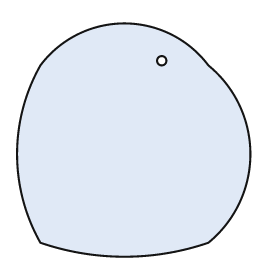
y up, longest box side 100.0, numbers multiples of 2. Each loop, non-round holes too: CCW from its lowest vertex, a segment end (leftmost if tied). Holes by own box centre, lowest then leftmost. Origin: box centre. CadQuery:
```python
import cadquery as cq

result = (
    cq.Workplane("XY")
    .moveTo(-40.0, -44.0)
    .threePointArc((-4.0, -50.0), (32.0, -44.0))
    .threePointArc((50.0, -6.0), (32.0, 32.0))
    .threePointArc((-4.0, 50.0), (-40.0, 32.0))
    .threePointArc((-50.0, -6.0), (-40.0, -44.0))
    .close()
    .moveTo(12.0, 34.0)
    .circle(2.0)
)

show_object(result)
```